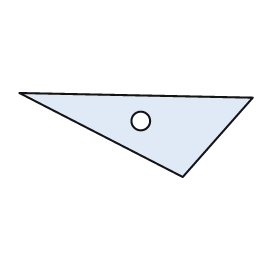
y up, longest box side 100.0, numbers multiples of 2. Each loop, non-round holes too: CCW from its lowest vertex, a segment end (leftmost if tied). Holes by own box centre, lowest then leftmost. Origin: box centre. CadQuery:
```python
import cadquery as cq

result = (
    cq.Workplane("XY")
    .moveTo(20.0, -18.0)
    .lineTo(50.0, 16.0)
    .lineTo(-50.0, 18.0)
    .close()
    .moveTo(2.0, 6.0)
    .circle(4.0)
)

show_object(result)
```